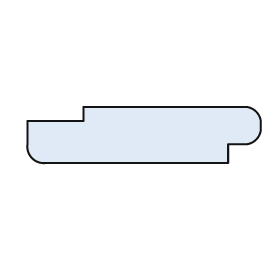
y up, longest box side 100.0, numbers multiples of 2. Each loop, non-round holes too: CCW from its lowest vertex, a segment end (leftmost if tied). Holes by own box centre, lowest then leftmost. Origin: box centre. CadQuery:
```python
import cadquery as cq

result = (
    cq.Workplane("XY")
    .moveTo(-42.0, -12.0)
    .lineTo(36.0, -12.0)
    .lineTo(36.0, -4.0)
    .lineTo(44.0, -4.0)
    .threePointArc((48.0, -2.0), (50.0, 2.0))
    .lineTo(50.0, 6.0)
    .threePointArc((48.0, 10.0), (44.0, 12.0))
    .lineTo(-26.0, 12.0)
    .lineTo(-26.0, 6.0)
    .lineTo(-50.0, 6.0)
    .lineTo(-50.0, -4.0)
    .threePointArc((-48.0, -10.0), (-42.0, -12.0))
    .close()
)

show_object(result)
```